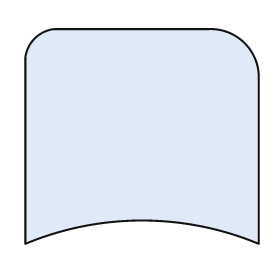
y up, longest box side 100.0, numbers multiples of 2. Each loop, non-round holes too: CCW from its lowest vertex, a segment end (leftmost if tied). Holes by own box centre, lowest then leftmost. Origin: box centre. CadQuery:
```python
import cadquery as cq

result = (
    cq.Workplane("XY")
    .moveTo(-50.0, -46.0)
    .threePointArc((0.0, -36.0), (50.0, -46.0))
    .lineTo(50.0, 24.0)
    .threePointArc((44.0, 40.0), (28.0, 46.0))
    .lineTo(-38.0, 46.0)
    .threePointArc((-46.0, 42.0), (-50.0, 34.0))
    .close()
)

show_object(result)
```